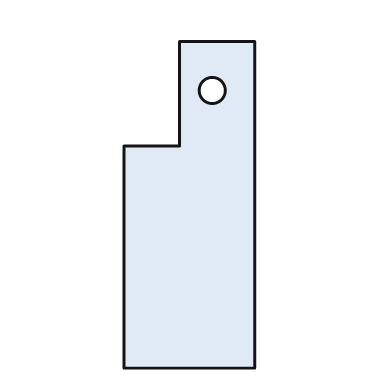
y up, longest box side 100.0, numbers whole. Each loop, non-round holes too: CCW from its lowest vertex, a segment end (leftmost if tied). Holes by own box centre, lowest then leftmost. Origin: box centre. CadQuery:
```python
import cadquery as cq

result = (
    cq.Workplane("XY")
    .moveTo(-20.0, -50.0)
    .lineTo(20.0, -50.0)
    .lineTo(20.0, 50.0)
    .lineTo(-3.0, 50.0)
    .lineTo(-3.0, 18.0)
    .lineTo(-20.0, 18.0)
    .close()
    .moveTo(7.0, 35.0)
    .circle(4.0)
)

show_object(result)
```